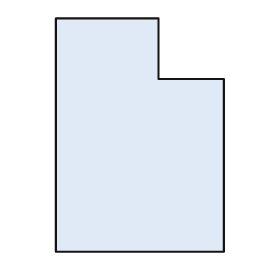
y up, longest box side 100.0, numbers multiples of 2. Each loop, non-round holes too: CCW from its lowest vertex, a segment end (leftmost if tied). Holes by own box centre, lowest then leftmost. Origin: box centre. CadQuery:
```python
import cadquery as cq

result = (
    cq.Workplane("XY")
    .moveTo(-36.0, -50.0)
    .lineTo(36.0, -50.0)
    .lineTo(36.0, 24.0)
    .lineTo(8.0, 24.0)
    .lineTo(8.0, 50.0)
    .lineTo(-36.0, 50.0)
    .close()
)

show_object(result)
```